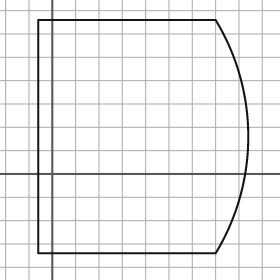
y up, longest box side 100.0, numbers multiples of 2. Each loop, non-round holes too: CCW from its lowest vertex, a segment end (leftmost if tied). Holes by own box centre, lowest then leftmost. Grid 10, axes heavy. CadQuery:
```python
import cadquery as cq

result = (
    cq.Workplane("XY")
    .moveTo(-6.0, -34.0)
    .lineTo(70.0, -34.0)
    .threePointArc((84.0, 16.0), (70.0, 66.0))
    .lineTo(-6.0, 66.0)
    .close()
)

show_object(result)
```